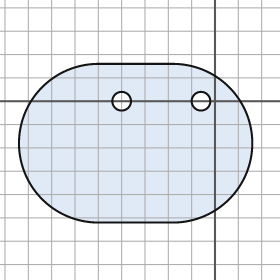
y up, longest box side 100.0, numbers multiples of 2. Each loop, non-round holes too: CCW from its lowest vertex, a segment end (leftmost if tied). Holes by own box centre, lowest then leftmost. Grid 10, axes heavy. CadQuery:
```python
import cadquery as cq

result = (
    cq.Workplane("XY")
    .moveTo(-50.0, -52.0)
    .lineTo(-18.0, -52.0)
    .threePointArc((16.0, -18.0), (-18.0, 16.0))
    .lineTo(-50.0, 16.0)
    .threePointArc((-84.0, -18.0), (-50.0, -52.0))
    .close()
    .moveTo(-40.0, 0.0)
    .circle(4.0)
    .moveTo(-6.0, 0.0)
    .circle(4.0)
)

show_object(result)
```